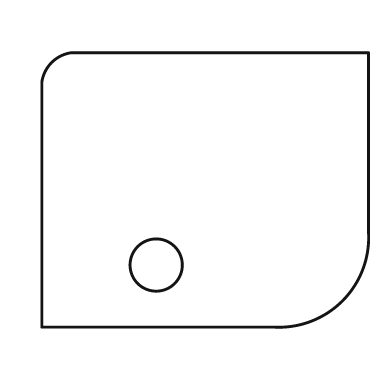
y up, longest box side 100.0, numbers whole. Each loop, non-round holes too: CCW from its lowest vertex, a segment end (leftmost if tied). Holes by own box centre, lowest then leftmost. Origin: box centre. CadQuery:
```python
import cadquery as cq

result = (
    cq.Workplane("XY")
    .moveTo(-50.0, -42.0)
    .lineTo(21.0, -42.0)
    .threePointArc((42.0, -34.0), (50.0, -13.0))
    .lineTo(50.0, 42.0)
    .lineTo(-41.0, 42.0)
    .threePointArc((-47.0, 39.0), (-50.0, 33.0))
    .close()
    .moveTo(-15.0, -23.0)
    .circle(8.0)
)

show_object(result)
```